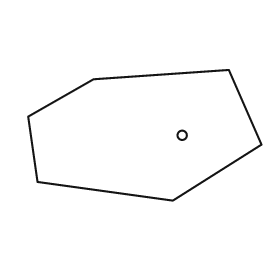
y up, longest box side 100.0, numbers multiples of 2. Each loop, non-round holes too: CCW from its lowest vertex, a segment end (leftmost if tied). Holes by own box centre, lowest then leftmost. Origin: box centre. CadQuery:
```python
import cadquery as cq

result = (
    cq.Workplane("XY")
    .moveTo(12.0, -28.0)
    .lineTo(50.0, -4.0)
    .lineTo(36.0, 28.0)
    .lineTo(-22.0, 24.0)
    .lineTo(-50.0, 8.0)
    .lineTo(-46.0, -20.0)
    .close()
    .moveTo(16.0, 0.0)
    .circle(2.0)
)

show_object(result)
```